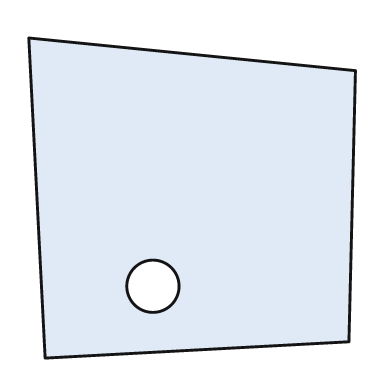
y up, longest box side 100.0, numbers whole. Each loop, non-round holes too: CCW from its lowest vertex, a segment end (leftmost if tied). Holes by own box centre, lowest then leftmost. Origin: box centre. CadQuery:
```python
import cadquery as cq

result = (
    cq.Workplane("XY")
    .moveTo(-45.0, -49.0)
    .lineTo(48.0, -44.0)
    .lineTo(50.0, 39.0)
    .lineTo(-50.0, 49.0)
    .close()
    .moveTo(-12.0, -27.0)
    .circle(8.0)
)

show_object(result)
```